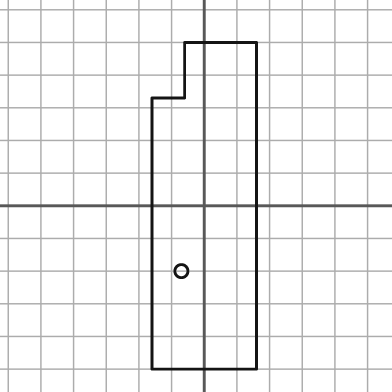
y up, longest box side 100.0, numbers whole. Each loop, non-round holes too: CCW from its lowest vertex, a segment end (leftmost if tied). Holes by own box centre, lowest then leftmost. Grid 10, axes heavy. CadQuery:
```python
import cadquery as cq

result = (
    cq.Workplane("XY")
    .moveTo(-16.0, -50.0)
    .lineTo(16.0, -50.0)
    .lineTo(16.0, 50.0)
    .lineTo(-6.0, 50.0)
    .lineTo(-6.0, 33.0)
    .lineTo(-16.0, 33.0)
    .close()
    .moveTo(-7.0, -20.0)
    .circle(2.0)
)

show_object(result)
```